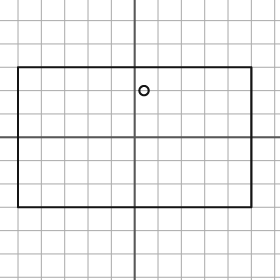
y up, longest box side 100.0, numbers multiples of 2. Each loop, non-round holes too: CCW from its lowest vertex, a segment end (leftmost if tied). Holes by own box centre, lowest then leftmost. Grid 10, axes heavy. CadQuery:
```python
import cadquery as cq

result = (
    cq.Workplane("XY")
    .moveTo(-50.0, -30.0)
    .lineTo(50.0, -30.0)
    .lineTo(50.0, 30.0)
    .lineTo(-50.0, 30.0)
    .close()
    .moveTo(4.0, 20.0)
    .circle(2.0)
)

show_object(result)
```